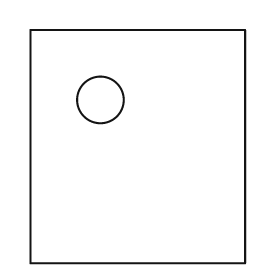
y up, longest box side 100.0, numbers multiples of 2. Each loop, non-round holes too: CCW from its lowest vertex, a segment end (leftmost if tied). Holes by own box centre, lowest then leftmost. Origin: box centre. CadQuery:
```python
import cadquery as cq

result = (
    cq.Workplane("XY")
    .moveTo(-46.0, -50.0)
    .lineTo(46.0, -50.0)
    .lineTo(46.0, 50.0)
    .lineTo(-46.0, 50.0)
    .close()
    .moveTo(-16.0, 20.0)
    .circle(10.0)
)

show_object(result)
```